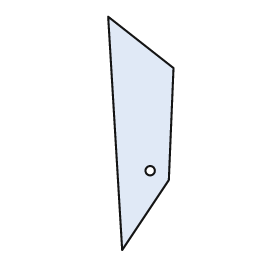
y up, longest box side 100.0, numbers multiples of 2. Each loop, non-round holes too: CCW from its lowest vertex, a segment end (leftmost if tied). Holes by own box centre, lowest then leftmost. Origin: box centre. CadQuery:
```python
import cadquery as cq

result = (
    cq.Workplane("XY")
    .moveTo(-8.0, -50.0)
    .lineTo(12.0, -20.0)
    .lineTo(14.0, 28.0)
    .lineTo(-14.0, 50.0)
    .close()
    .moveTo(4.0, -16.0)
    .circle(2.0)
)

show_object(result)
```